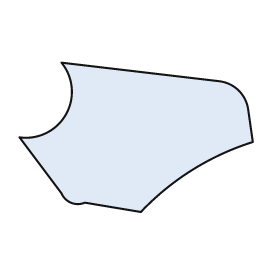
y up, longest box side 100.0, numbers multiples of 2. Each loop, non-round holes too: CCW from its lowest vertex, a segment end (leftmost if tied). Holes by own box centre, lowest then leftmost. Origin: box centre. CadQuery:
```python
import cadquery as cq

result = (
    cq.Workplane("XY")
    .moveTo(2.0, -32.0)
    .threePointArc((24.0, -14.0), (50.0, -2.0))
    .lineTo(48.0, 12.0)
    .threePointArc((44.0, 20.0), (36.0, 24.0))
    .lineTo(-32.0, 32.0)
    .threePointArc((-30.0, 10.0), (-50.0, 0.0))
    .lineTo(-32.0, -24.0)
    .threePointArc((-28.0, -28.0), (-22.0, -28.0))
    .close()
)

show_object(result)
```